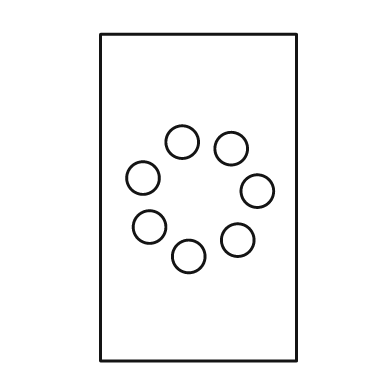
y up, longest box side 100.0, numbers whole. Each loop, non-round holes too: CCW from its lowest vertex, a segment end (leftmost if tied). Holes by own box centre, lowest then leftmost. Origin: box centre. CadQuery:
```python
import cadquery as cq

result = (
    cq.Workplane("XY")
    .moveTo(-30.0, -50.0)
    .lineTo(30.0, -50.0)
    .lineTo(30.0, 50.0)
    .lineTo(-30.0, 50.0)
    .close()
    .moveTo(-3.0, -18.0)
    .circle(5.0)
    .moveTo(12.0, -13.0)
    .circle(5.0)
    .moveTo(-15.0, -9.0)
    .circle(5.0)
    .moveTo(18.0, 2.0)
    .circle(5.0)
    .moveTo(-17.0, 6.0)
    .circle(5.0)
    .moveTo(10.0, 15.0)
    .circle(5.0)
    .moveTo(-5.0, 17.0)
    .circle(5.0)
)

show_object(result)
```